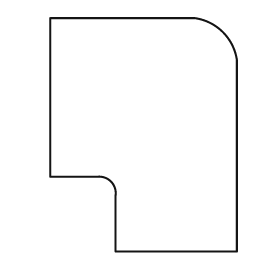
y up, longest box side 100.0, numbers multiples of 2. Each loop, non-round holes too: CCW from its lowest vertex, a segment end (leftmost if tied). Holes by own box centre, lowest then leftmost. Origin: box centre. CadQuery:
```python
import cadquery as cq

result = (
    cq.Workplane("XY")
    .moveTo(-12.0, -50.0)
    .lineTo(40.0, -50.0)
    .lineTo(40.0, 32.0)
    .threePointArc((34.0, 44.0), (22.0, 50.0))
    .lineTo(-40.0, 50.0)
    .lineTo(-40.0, -18.0)
    .lineTo(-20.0, -18.0)
    .threePointArc((-14.0, -20.0), (-12.0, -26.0))
    .close()
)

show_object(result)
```